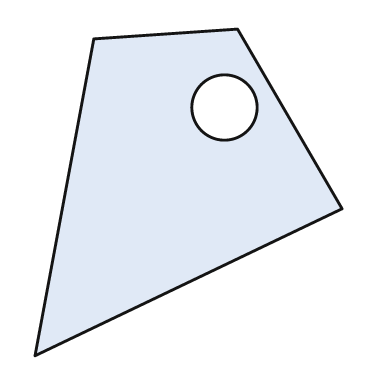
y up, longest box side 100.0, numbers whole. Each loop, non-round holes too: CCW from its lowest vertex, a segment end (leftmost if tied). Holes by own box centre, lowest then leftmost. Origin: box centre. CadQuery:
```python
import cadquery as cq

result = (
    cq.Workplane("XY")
    .moveTo(-47.0, -50.0)
    .lineTo(47.0, -5.0)
    .lineTo(15.0, 50.0)
    .lineTo(-29.0, 47.0)
    .close()
    .moveTo(11.0, 26.0)
    .circle(10.0)
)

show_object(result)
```